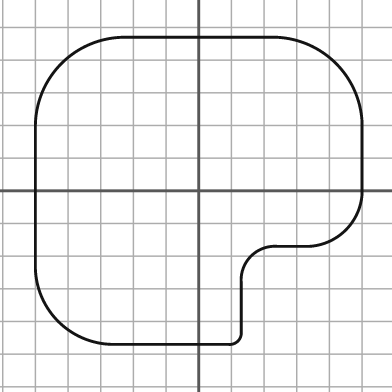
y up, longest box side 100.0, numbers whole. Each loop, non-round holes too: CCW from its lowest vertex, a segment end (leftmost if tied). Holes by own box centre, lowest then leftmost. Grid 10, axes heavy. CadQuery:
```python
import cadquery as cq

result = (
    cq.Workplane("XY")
    .moveTo(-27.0, -47.0)
    .lineTo(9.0, -47.0)
    .threePointArc((12.0, -46.0), (13.0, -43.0))
    .lineTo(13.0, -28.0)
    .threePointArc((16.0, -20.0), (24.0, -17.0))
    .lineTo(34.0, -17.0)
    .threePointArc((45.0, -12.0), (50.0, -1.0))
    .lineTo(50.0, 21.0)
    .threePointArc((42.0, 39.0), (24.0, 47.0))
    .lineTo(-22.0, 47.0)
    .threePointArc((-42.0, 39.0), (-50.0, 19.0))
    .lineTo(-50.0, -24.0)
    .threePointArc((-43.0, -40.0), (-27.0, -47.0))
    .close()
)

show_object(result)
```